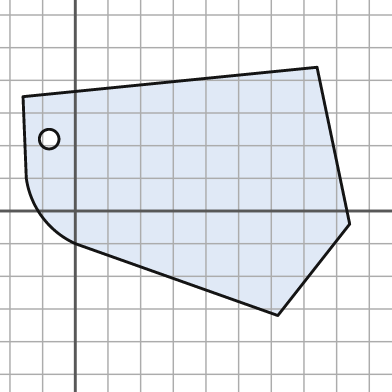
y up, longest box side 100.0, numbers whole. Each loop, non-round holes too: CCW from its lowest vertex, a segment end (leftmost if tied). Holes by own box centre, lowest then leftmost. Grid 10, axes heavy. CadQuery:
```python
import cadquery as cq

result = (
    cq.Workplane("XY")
    .moveTo(62.0, -32.0)
    .lineTo(84.0, -4.0)
    .lineTo(74.0, 44.0)
    .lineTo(-16.0, 35.0)
    .lineTo(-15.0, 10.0)
    .threePointArc((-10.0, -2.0), (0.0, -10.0))
    .close()
    .moveTo(-8.0, 22.0)
    .circle(3.0)
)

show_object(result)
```